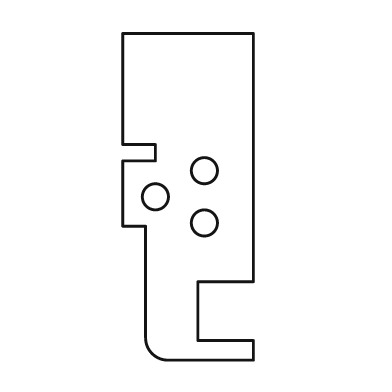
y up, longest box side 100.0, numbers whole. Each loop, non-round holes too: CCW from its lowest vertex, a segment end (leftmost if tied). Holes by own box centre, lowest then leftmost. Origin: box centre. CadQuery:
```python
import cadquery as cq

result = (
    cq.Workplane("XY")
    .moveTo(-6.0, -50.0)
    .lineTo(20.0, -50.0)
    .lineTo(20.0, -44.0)
    .lineTo(3.0, -44.0)
    .lineTo(3.0, -26.0)
    .lineTo(20.0, -26.0)
    .lineTo(20.0, 50.0)
    .lineTo(-20.0, 50.0)
    .lineTo(-20.0, 16.0)
    .lineTo(-10.0, 16.0)
    .lineTo(-10.0, 11.0)
    .lineTo(-20.0, 11.0)
    .lineTo(-20.0, -9.0)
    .lineTo(-13.0, -9.0)
    .lineTo(-13.0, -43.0)
    .threePointArc((-11.0, -48.0), (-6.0, -50.0))
    .close()
    .moveTo(5.0, -8.0)
    .circle(4.0)
    .moveTo(-10.0, 0.0)
    .circle(4.0)
    .moveTo(5.0, 8.0)
    .circle(4.0)
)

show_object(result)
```